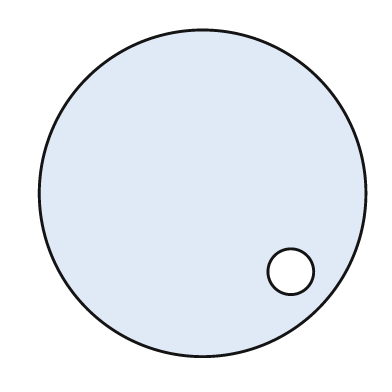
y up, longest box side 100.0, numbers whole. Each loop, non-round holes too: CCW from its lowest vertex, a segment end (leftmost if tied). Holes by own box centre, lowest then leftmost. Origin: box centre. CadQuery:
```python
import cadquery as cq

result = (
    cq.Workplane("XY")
    .moveTo(0.0, 0.0)
    .circle(50.0)
    .moveTo(27.0, -24.0)
    .circle(7.0)
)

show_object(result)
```